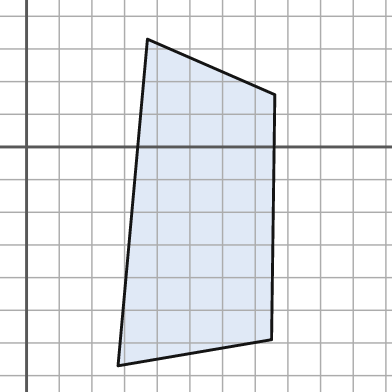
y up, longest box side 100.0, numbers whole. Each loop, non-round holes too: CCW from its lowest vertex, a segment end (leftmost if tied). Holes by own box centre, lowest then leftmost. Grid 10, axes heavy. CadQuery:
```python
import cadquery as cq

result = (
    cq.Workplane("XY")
    .moveTo(28.0, -67.0)
    .lineTo(75.0, -59.0)
    .lineTo(76.0, 16.0)
    .lineTo(37.0, 33.0)
    .close()
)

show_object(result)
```